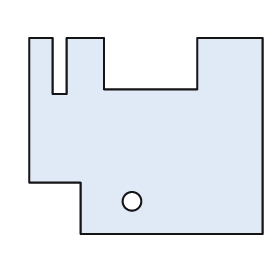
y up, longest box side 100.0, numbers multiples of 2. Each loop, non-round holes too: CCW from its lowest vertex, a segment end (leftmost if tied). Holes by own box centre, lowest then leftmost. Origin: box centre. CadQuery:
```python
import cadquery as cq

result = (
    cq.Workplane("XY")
    .moveTo(-28.0, -42.0)
    .lineTo(50.0, -42.0)
    .lineTo(50.0, 42.0)
    .lineTo(22.0, 42.0)
    .lineTo(22.0, 20.0)
    .lineTo(-18.0, 20.0)
    .lineTo(-18.0, 42.0)
    .lineTo(-34.0, 42.0)
    .lineTo(-34.0, 18.0)
    .lineTo(-40.0, 18.0)
    .lineTo(-40.0, 42.0)
    .lineTo(-50.0, 42.0)
    .lineTo(-50.0, -20.0)
    .lineTo(-28.0, -20.0)
    .close()
    .moveTo(-6.0, -28.0)
    .circle(4.0)
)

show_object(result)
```